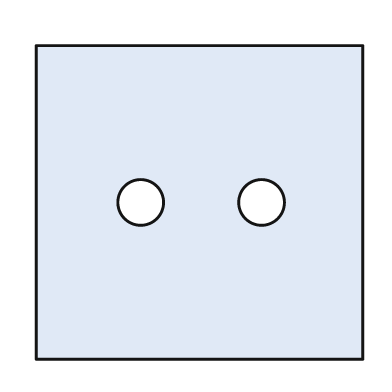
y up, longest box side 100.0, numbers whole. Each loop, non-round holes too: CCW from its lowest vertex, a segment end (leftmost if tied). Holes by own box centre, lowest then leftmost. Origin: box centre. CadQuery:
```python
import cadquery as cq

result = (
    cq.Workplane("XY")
    .moveTo(-50.0, -48.0)
    .lineTo(50.0, -48.0)
    .lineTo(50.0, 48.0)
    .lineTo(-50.0, 48.0)
    .close()
    .moveTo(-18.0, 0.0)
    .circle(7.0)
    .moveTo(19.0, 0.0)
    .circle(7.0)
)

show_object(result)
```